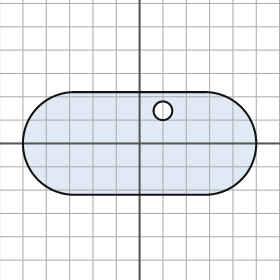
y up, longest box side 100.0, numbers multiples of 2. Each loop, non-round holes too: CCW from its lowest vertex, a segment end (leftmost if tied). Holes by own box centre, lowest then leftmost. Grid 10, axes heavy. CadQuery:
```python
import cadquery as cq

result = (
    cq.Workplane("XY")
    .moveTo(-28.0, -22.0)
    .lineTo(28.0, -22.0)
    .threePointArc((50.0, 0.0), (28.0, 22.0))
    .lineTo(-28.0, 22.0)
    .threePointArc((-50.0, 0.0), (-28.0, -22.0))
    .close()
    .moveTo(10.0, 14.0)
    .circle(4.0)
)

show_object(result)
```